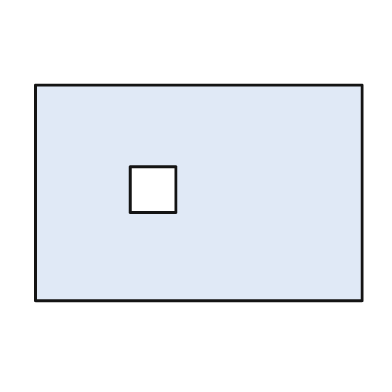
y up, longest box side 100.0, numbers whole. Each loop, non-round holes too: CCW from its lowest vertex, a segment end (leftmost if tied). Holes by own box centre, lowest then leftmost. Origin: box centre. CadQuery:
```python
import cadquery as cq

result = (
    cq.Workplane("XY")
    .moveTo(-50.0, -33.0)
    .lineTo(50.0, -33.0)
    .lineTo(50.0, 33.0)
    .lineTo(-50.0, 33.0)
    .close()
    .moveTo(-21.0, -6.0)
    .lineTo(-7.0, -6.0)
    .lineTo(-7.0, 8.0)
    .lineTo(-21.0, 8.0)
    .close()
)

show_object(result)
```